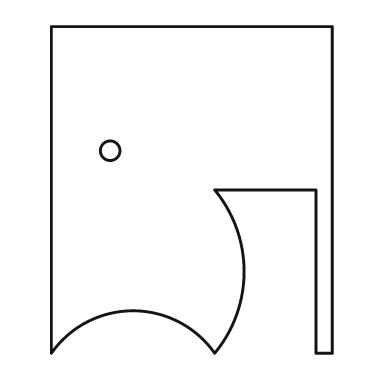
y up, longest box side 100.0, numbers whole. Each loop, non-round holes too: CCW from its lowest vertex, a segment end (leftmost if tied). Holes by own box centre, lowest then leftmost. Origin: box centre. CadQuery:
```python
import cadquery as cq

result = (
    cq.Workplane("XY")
    .moveTo(-43.0, -50.0)
    .threePointArc((-18.0, -37.0), (7.0, -50.0))
    .threePointArc((16.0, -25.0), (7.0, 0.0))
    .lineTo(38.0, 0.0)
    .lineTo(38.0, -50.0)
    .lineTo(43.0, -50.0)
    .lineTo(43.0, 50.0)
    .lineTo(-43.0, 50.0)
    .close()
    .moveTo(-25.0, 12.0)
    .circle(3.0)
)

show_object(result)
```